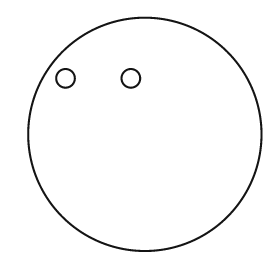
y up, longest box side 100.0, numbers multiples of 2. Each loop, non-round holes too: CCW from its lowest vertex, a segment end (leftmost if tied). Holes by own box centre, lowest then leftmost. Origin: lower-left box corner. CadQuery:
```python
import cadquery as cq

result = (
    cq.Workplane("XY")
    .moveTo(50.0, 50.0)
    .circle(50.0)
    .moveTo(16.0, 74.0)
    .circle(4.0)
    .moveTo(44.0, 74.0)
    .circle(4.0)
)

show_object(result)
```